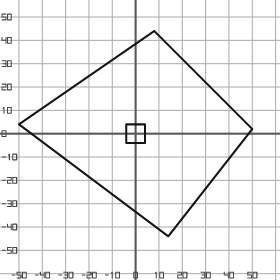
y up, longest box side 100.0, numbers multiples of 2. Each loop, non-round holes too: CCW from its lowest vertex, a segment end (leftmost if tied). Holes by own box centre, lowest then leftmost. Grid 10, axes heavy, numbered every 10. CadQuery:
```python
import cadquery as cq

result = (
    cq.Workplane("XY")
    .moveTo(14.0, -44.0)
    .lineTo(50.0, 2.0)
    .lineTo(8.0, 44.0)
    .lineTo(-50.0, 4.0)
    .close()
    .moveTo(-4.0, -4.0)
    .lineTo(4.0, -4.0)
    .lineTo(4.0, 4.0)
    .lineTo(-4.0, 4.0)
    .close()
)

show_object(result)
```